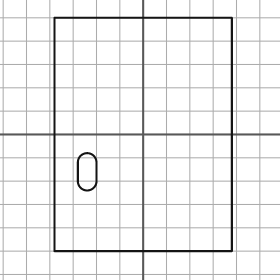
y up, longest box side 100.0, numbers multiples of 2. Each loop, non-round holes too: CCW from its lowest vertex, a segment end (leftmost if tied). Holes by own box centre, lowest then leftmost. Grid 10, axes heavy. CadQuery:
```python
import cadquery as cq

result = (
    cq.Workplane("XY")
    .moveTo(-38.0, -50.0)
    .lineTo(38.0, -50.0)
    .lineTo(38.0, 50.0)
    .lineTo(-38.0, 50.0)
    .close()
    .moveTo(-28.0, -20.0)
    .threePointArc((-24.0, -24.0), (-20.0, -20.0))
    .lineTo(-20.0, -12.0)
    .threePointArc((-24.0, -8.0), (-28.0, -12.0))
    .close()
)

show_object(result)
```